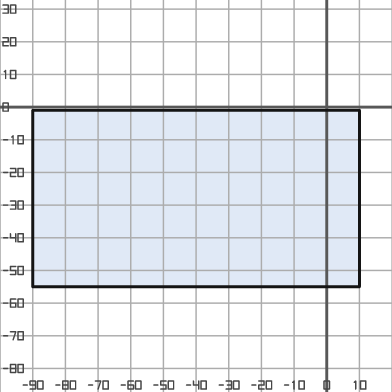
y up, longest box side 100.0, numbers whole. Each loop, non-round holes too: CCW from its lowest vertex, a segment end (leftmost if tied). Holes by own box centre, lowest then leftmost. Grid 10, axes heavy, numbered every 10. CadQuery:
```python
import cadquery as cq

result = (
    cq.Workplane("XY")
    .moveTo(-90.0, -55.0)
    .lineTo(10.0, -55.0)
    .lineTo(10.0, -1.0)
    .lineTo(-90.0, -1.0)
    .close()
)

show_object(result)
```